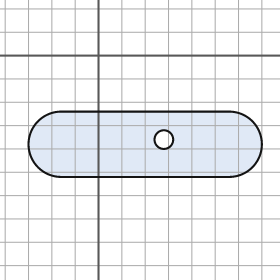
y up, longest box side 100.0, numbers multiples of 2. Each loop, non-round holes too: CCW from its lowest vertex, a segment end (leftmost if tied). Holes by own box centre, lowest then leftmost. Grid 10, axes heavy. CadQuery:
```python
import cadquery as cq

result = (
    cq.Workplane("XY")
    .moveTo(-16.0, -52.0)
    .lineTo(56.0, -52.0)
    .threePointArc((70.0, -38.0), (56.0, -24.0))
    .lineTo(-16.0, -24.0)
    .threePointArc((-30.0, -38.0), (-16.0, -52.0))
    .close()
    .moveTo(28.0, -36.0)
    .circle(4.0)
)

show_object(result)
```